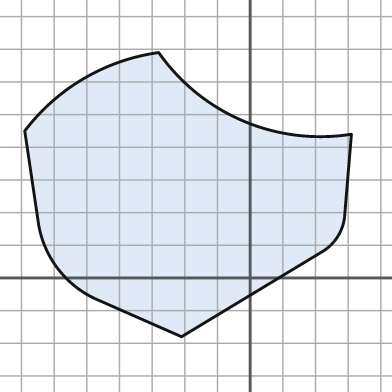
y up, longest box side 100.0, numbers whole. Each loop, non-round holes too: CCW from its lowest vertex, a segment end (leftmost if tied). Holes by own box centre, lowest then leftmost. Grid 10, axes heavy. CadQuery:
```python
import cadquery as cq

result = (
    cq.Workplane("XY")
    .moveTo(-21.0, -18.0)
    .lineTo(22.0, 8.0)
    .threePointArc((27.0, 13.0), (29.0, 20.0))
    .lineTo(31.0, 44.0)
    .threePointArc((-2.0, 48.0), (-28.0, 69.0))
    .threePointArc((-51.0, 61.0), (-69.0, 45.0))
    .lineTo(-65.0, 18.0)
    .threePointArc((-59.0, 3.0), (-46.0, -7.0))
    .close()
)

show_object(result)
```